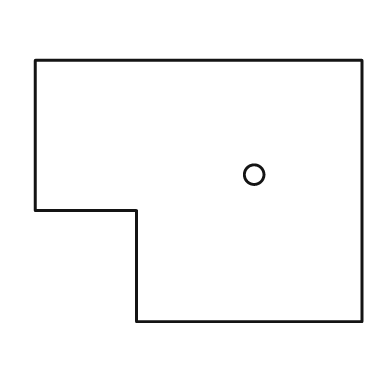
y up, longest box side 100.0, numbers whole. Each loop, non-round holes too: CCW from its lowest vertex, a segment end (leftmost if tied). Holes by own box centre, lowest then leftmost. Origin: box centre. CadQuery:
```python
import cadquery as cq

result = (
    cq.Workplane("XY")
    .moveTo(-19.0, -40.0)
    .lineTo(50.0, -40.0)
    .lineTo(50.0, 40.0)
    .lineTo(-50.0, 40.0)
    .lineTo(-50.0, -6.0)
    .lineTo(-19.0, -6.0)
    .close()
    .moveTo(17.0, 5.0)
    .circle(3.0)
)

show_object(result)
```